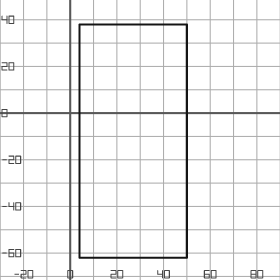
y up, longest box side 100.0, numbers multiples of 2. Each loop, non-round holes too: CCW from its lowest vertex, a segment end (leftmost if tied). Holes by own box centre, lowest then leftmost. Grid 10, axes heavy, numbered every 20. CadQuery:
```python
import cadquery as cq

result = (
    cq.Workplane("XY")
    .moveTo(4.0, -62.0)
    .lineTo(50.0, -62.0)
    .lineTo(50.0, 38.0)
    .lineTo(4.0, 38.0)
    .close()
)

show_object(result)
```